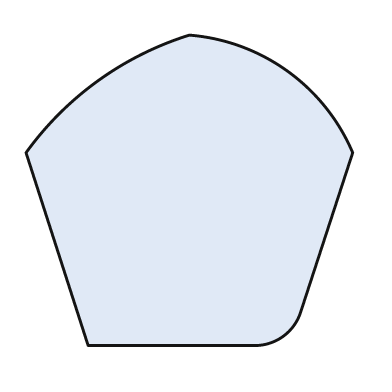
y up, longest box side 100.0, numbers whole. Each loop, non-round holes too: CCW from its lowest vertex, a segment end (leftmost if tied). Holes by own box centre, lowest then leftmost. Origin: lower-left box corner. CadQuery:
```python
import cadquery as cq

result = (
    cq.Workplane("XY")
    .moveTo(19.0, 0.0)
    .lineTo(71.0, 0.0)
    .threePointArc((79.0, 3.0), (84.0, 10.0))
    .lineTo(100.0, 59.0)
    .threePointArc((80.0, 84.0), (50.0, 95.0))
    .threePointArc((22.0, 81.0), (0.0, 59.0))
    .close()
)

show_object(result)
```